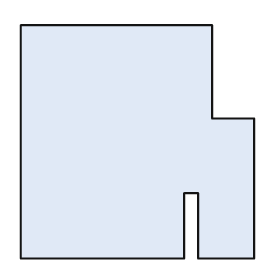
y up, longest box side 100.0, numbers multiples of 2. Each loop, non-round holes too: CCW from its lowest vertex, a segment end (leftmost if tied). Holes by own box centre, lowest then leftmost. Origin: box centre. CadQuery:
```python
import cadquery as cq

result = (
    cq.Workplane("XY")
    .moveTo(-50.0, -50.0)
    .lineTo(20.0, -50.0)
    .lineTo(20.0, -22.0)
    .lineTo(26.0, -22.0)
    .lineTo(26.0, -50.0)
    .lineTo(50.0, -50.0)
    .lineTo(50.0, 10.0)
    .lineTo(32.0, 10.0)
    .lineTo(32.0, 50.0)
    .lineTo(-50.0, 50.0)
    .close()
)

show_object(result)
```